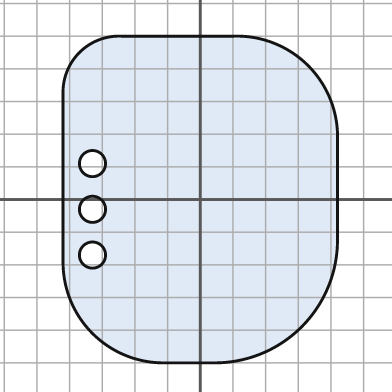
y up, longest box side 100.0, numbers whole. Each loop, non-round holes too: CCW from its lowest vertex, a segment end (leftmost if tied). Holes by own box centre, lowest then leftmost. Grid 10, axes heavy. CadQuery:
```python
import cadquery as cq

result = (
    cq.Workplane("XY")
    .moveTo(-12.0, -50.0)
    .lineTo(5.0, -50.0)
    .threePointArc((31.0, -39.0), (42.0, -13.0))
    .lineTo(42.0, 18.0)
    .threePointArc((33.0, 41.0), (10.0, 50.0))
    .lineTo(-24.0, 50.0)
    .threePointArc((-37.0, 45.0), (-42.0, 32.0))
    .lineTo(-42.0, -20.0)
    .threePointArc((-33.0, -41.0), (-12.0, -50.0))
    .close()
    .moveTo(-33.0, -17.0)
    .circle(4.0)
    .moveTo(-33.0, -3.0)
    .circle(4.0)
    .moveTo(-33.0, 11.0)
    .circle(4.0)
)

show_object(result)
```